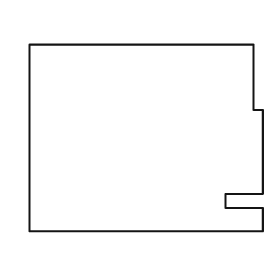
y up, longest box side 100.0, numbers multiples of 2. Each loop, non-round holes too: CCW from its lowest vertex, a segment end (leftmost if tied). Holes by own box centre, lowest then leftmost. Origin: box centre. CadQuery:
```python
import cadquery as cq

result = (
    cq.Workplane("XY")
    .moveTo(-50.0, -40.0)
    .lineTo(50.0, -40.0)
    .lineTo(50.0, -30.0)
    .lineTo(34.0, -30.0)
    .lineTo(34.0, -24.0)
    .lineTo(50.0, -24.0)
    .lineTo(50.0, 12.0)
    .lineTo(46.0, 12.0)
    .lineTo(46.0, 40.0)
    .lineTo(-50.0, 40.0)
    .close()
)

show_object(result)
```